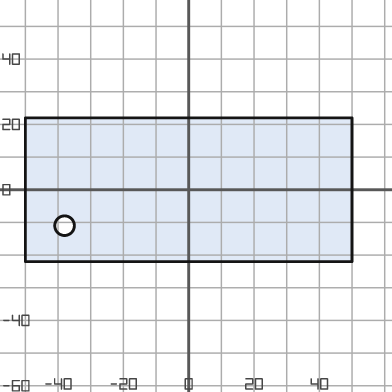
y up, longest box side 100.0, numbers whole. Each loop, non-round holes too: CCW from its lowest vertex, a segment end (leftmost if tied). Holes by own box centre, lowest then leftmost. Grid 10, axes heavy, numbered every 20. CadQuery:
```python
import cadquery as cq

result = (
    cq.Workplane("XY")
    .moveTo(-50.0, -22.0)
    .lineTo(50.0, -22.0)
    .lineTo(50.0, 22.0)
    .lineTo(-50.0, 22.0)
    .close()
    .moveTo(-38.0, -11.0)
    .circle(3.0)
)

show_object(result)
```